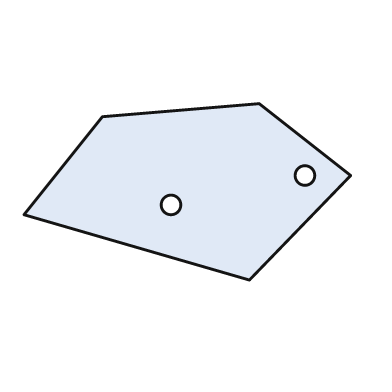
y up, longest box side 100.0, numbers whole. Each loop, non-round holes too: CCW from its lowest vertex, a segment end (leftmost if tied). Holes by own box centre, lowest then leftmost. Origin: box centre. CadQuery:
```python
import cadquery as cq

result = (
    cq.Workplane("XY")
    .moveTo(19.0, -27.0)
    .lineTo(50.0, 5.0)
    .lineTo(22.0, 27.0)
    .lineTo(-26.0, 23.0)
    .lineTo(-50.0, -7.0)
    .close()
    .moveTo(-5.0, -4.0)
    .circle(3.0)
    .moveTo(36.0, 5.0)
    .circle(3.0)
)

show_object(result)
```